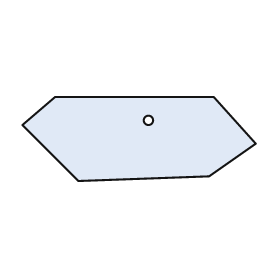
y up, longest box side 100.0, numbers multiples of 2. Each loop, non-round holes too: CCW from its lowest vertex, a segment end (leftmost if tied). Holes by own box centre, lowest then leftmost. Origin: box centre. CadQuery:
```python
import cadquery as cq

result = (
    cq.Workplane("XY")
    .moveTo(-26.0, -18.0)
    .lineTo(30.0, -16.0)
    .lineTo(50.0, -2.0)
    .lineTo(32.0, 18.0)
    .lineTo(-36.0, 18.0)
    .lineTo(-50.0, 6.0)
    .close()
    .moveTo(4.0, 8.0)
    .circle(2.0)
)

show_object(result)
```